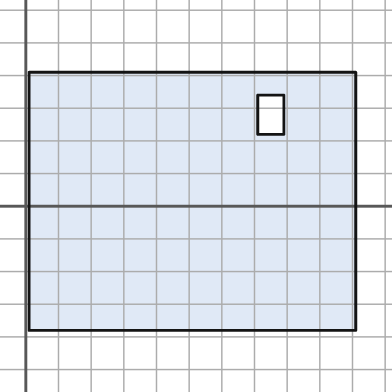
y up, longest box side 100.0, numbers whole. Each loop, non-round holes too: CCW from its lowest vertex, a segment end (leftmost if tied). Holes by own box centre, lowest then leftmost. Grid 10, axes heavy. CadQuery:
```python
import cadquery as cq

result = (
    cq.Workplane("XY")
    .moveTo(1.0, -38.0)
    .lineTo(101.0, -38.0)
    .lineTo(101.0, 41.0)
    .lineTo(1.0, 41.0)
    .close()
    .moveTo(71.0, 22.0)
    .lineTo(79.0, 22.0)
    .lineTo(79.0, 34.0)
    .lineTo(71.0, 34.0)
    .close()
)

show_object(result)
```